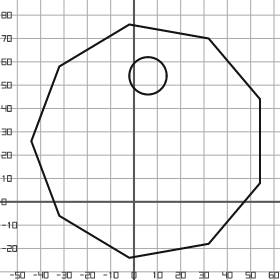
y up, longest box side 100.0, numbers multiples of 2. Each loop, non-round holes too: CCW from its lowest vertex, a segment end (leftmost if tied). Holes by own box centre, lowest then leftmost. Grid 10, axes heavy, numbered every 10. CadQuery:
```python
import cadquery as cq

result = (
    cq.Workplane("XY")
    .moveTo(-2.0, -24.0)
    .lineTo(32.0, -18.0)
    .lineTo(54.0, 8.0)
    .lineTo(54.0, 44.0)
    .lineTo(32.0, 70.0)
    .lineTo(-2.0, 76.0)
    .lineTo(-32.0, 58.0)
    .lineTo(-44.0, 26.0)
    .lineTo(-32.0, -6.0)
    .close()
    .moveTo(6.0, 54.0)
    .circle(8.0)
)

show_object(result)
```